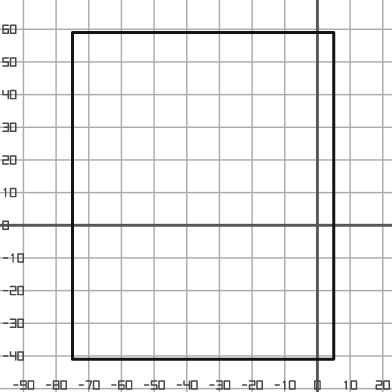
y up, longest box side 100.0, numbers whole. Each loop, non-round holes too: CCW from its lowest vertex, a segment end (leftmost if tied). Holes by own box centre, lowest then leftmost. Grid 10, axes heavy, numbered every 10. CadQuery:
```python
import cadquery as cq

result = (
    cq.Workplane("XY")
    .moveTo(-75.0, -41.0)
    .lineTo(5.0, -41.0)
    .lineTo(5.0, 59.0)
    .lineTo(-75.0, 59.0)
    .close()
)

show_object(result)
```